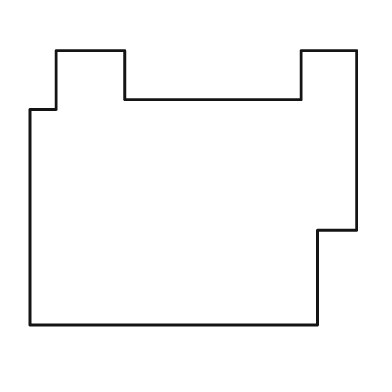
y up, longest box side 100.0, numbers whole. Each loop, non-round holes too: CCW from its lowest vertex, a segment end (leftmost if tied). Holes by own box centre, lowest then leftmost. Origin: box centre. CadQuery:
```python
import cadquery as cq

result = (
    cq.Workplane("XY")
    .moveTo(-50.0, -42.0)
    .lineTo(38.0, -42.0)
    .lineTo(38.0, -13.0)
    .lineTo(50.0, -13.0)
    .lineTo(50.0, 42.0)
    .lineTo(33.0, 42.0)
    .lineTo(33.0, 27.0)
    .lineTo(-21.0, 27.0)
    .lineTo(-21.0, 42.0)
    .lineTo(-42.0, 42.0)
    .lineTo(-42.0, 24.0)
    .lineTo(-50.0, 24.0)
    .close()
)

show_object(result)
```